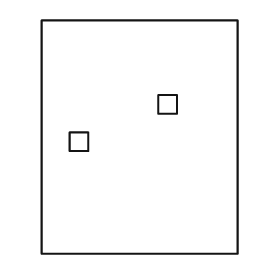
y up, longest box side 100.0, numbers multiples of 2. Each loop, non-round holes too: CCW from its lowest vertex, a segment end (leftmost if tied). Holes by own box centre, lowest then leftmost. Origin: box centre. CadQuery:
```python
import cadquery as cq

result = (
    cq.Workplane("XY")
    .moveTo(-42.0, -50.0)
    .lineTo(42.0, -50.0)
    .lineTo(42.0, 50.0)
    .lineTo(-42.0, 50.0)
    .close()
    .moveTo(-30.0, -6.0)
    .lineTo(-22.0, -6.0)
    .lineTo(-22.0, 2.0)
    .lineTo(-30.0, 2.0)
    .close()
    .moveTo(8.0, 10.0)
    .lineTo(16.0, 10.0)
    .lineTo(16.0, 18.0)
    .lineTo(8.0, 18.0)
    .close()
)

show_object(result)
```